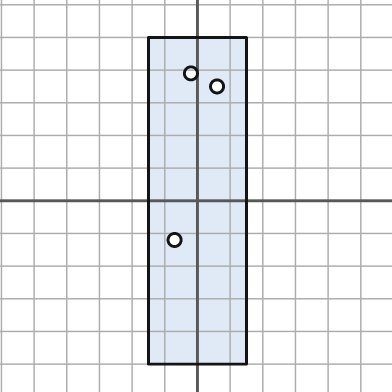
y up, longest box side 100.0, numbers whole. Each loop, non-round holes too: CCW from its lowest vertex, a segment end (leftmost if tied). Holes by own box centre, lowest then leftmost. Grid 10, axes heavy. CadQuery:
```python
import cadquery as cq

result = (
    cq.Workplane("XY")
    .moveTo(-15.0, -50.0)
    .lineTo(15.0, -50.0)
    .lineTo(15.0, 50.0)
    .lineTo(-15.0, 50.0)
    .close()
    .moveTo(-7.0, -12.0)
    .circle(2.0)
    .moveTo(6.0, 35.0)
    .circle(2.0)
    .moveTo(-2.0, 39.0)
    .circle(2.0)
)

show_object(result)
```